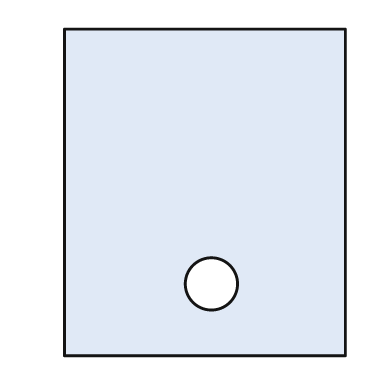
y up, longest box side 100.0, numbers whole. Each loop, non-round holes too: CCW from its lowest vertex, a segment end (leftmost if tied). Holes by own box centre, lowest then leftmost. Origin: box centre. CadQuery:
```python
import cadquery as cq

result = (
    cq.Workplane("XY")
    .moveTo(-43.0, -50.0)
    .lineTo(43.0, -50.0)
    .lineTo(43.0, 50.0)
    .lineTo(-43.0, 50.0)
    .close()
    .moveTo(2.0, -28.0)
    .circle(8.0)
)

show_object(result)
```